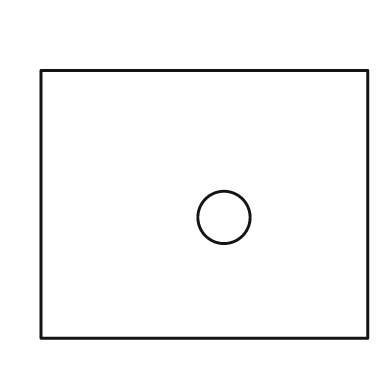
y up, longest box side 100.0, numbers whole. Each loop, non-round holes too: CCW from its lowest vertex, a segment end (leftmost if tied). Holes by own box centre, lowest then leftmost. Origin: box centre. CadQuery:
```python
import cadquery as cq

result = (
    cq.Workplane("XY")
    .moveTo(-50.0, -41.0)
    .lineTo(50.0, -41.0)
    .lineTo(50.0, 41.0)
    .lineTo(-50.0, 41.0)
    .close()
    .moveTo(6.0, -4.0)
    .circle(8.0)
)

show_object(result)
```